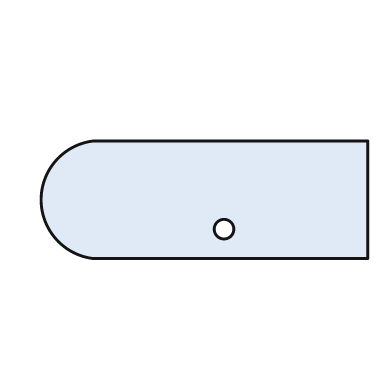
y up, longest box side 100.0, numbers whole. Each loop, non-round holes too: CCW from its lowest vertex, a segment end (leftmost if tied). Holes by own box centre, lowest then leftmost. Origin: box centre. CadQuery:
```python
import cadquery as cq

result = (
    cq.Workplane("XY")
    .moveTo(-34.0, -18.0)
    .lineTo(50.0, -18.0)
    .lineTo(50.0, 18.0)
    .lineTo(-34.0, 18.0)
    .threePointArc((-50.0, 0.0), (-34.0, -18.0))
    .close()
    .moveTo(6.0, -9.0)
    .circle(3.0)
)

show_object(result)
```